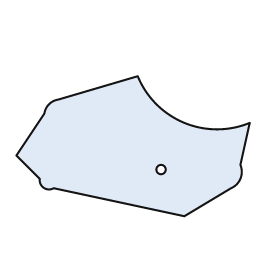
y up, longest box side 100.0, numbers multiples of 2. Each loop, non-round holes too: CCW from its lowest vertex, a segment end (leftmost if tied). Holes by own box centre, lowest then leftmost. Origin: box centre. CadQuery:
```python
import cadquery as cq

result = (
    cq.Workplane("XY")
    .moveTo(22.0, -30.0)
    .lineTo(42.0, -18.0)
    .threePointArc((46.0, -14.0), (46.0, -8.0))
    .lineTo(50.0, 10.0)
    .threePointArc((22.0, 10.0), (2.0, 30.0))
    .lineTo(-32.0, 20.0)
    .threePointArc((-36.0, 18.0), (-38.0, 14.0))
    .lineTo(-50.0, -4.0)
    .lineTo(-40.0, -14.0)
    .threePointArc((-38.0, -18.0), (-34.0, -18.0))
    .close()
    .moveTo(12.0, -10.0)
    .circle(2.0)
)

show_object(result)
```